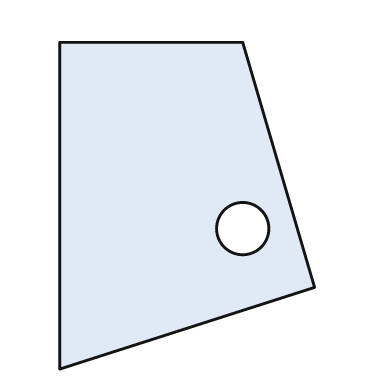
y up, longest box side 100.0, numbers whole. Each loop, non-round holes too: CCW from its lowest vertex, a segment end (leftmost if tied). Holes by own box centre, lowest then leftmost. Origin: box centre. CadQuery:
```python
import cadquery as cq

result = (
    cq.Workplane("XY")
    .moveTo(-39.0, -50.0)
    .lineTo(39.0, -25.0)
    .lineTo(17.0, 50.0)
    .lineTo(-39.0, 50.0)
    .close()
    .moveTo(17.0, -7.0)
    .circle(8.0)
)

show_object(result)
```